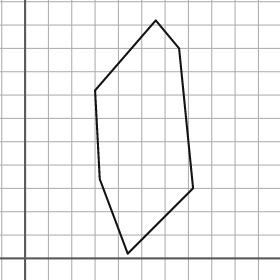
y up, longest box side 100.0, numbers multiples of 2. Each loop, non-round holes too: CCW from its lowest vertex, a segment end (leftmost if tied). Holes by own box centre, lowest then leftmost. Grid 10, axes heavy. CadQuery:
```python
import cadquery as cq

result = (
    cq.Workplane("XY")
    .moveTo(44.0, 2.0)
    .lineTo(72.0, 30.0)
    .lineTo(66.0, 90.0)
    .lineTo(56.0, 102.0)
    .lineTo(30.0, 72.0)
    .lineTo(32.0, 34.0)
    .close()
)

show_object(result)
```